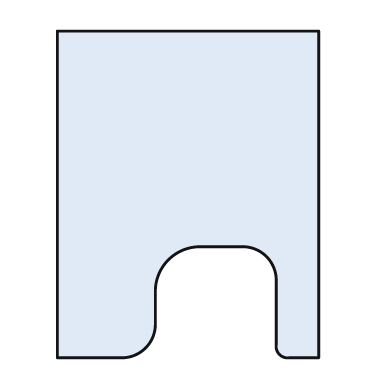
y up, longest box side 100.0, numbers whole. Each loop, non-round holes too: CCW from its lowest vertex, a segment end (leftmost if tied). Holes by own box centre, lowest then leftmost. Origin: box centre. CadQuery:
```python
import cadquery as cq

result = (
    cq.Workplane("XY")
    .moveTo(-40.0, -50.0)
    .lineTo(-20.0, -50.0)
    .threePointArc((-13.0, -47.0), (-10.0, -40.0))
    .lineTo(-10.0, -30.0)
    .threePointArc((-6.0, -20.0), (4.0, -16.0))
    .lineTo(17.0, -16.0)
    .threePointArc((24.0, -19.0), (27.0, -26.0))
    .lineTo(27.0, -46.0)
    .threePointArc((28.0, -49.0), (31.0, -50.0))
    .lineTo(40.0, -50.0)
    .lineTo(40.0, 50.0)
    .lineTo(-40.0, 50.0)
    .close()
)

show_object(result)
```